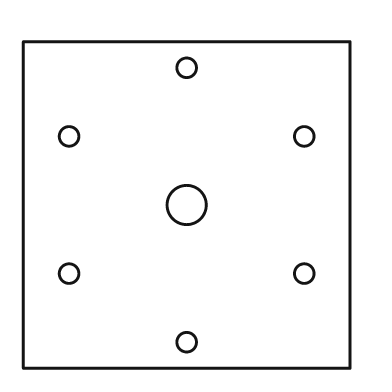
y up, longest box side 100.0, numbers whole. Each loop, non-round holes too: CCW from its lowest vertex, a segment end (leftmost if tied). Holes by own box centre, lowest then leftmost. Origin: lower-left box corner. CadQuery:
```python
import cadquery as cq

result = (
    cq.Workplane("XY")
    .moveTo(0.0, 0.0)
    .lineTo(100.0, 0.0)
    .lineTo(100.0, 100.0)
    .lineTo(0.0, 100.0)
    .close()
    .moveTo(50.0, 8.0)
    .circle(3.0)
    .moveTo(14.0, 29.0)
    .circle(3.0)
    .moveTo(86.0, 29.0)
    .circle(3.0)
    .moveTo(50.0, 50.0)
    .circle(6.0)
    .moveTo(14.0, 71.0)
    .circle(3.0)
    .moveTo(86.0, 71.0)
    .circle(3.0)
    .moveTo(50.0, 92.0)
    .circle(3.0)
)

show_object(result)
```